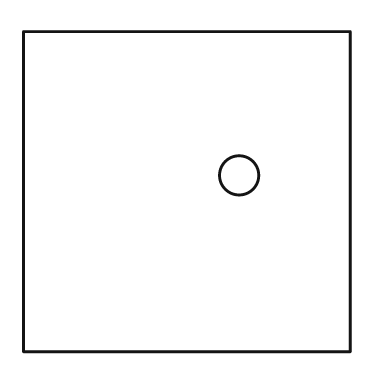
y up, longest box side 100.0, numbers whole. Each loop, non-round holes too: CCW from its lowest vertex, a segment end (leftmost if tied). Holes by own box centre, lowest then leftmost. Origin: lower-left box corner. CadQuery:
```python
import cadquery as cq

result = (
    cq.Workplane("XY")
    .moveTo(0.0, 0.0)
    .lineTo(100.0, 0.0)
    .lineTo(100.0, 98.0)
    .lineTo(0.0, 98.0)
    .close()
    .moveTo(66.0, 54.0)
    .circle(6.0)
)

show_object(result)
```